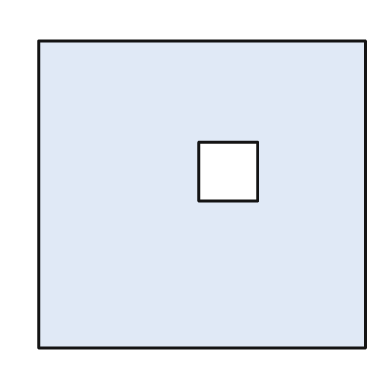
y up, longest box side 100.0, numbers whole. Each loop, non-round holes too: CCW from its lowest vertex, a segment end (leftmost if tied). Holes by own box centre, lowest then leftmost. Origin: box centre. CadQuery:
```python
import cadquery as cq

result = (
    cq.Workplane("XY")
    .moveTo(-50.0, -47.0)
    .lineTo(50.0, -47.0)
    .lineTo(50.0, 47.0)
    .lineTo(-50.0, 47.0)
    .close()
    .moveTo(-1.0, -2.0)
    .lineTo(17.0, -2.0)
    .lineTo(17.0, 16.0)
    .lineTo(-1.0, 16.0)
    .close()
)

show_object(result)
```